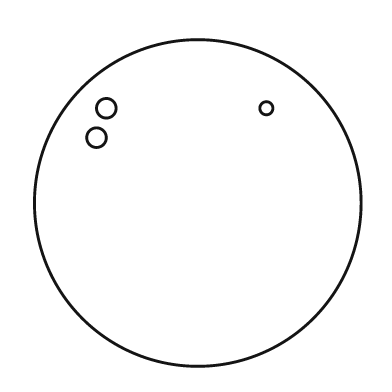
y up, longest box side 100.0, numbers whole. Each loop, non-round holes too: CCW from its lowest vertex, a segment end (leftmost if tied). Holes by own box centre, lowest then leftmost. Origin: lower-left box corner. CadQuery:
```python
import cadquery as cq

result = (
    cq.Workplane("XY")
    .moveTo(50.0, 50.0)
    .circle(50.0)
    .moveTo(19.0, 70.0)
    .circle(3.0)
    .moveTo(22.0, 79.0)
    .circle(3.0)
    .moveTo(71.0, 79.0)
    .circle(2.0)
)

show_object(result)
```